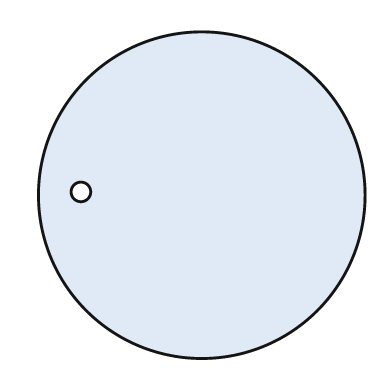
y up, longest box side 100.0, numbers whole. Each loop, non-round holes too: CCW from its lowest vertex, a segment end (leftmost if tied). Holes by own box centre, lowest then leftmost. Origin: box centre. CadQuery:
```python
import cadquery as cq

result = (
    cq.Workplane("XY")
    .moveTo(0.0, 0.0)
    .circle(50.0)
    .moveTo(-37.0, 1.0)
    .circle(3.0)
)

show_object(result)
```